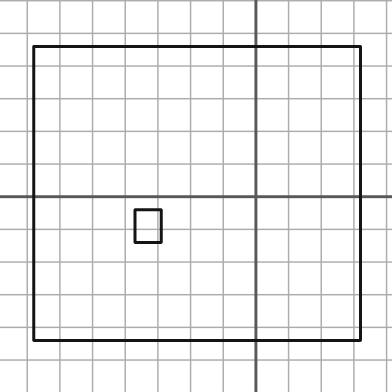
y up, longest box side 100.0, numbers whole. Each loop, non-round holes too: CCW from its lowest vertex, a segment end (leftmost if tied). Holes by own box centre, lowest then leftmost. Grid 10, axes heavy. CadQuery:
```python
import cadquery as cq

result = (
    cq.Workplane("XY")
    .moveTo(-68.0, -44.0)
    .lineTo(32.0, -44.0)
    .lineTo(32.0, 46.0)
    .lineTo(-68.0, 46.0)
    .close()
    .moveTo(-37.0, -14.0)
    .lineTo(-29.0, -14.0)
    .lineTo(-29.0, -4.0)
    .lineTo(-37.0, -4.0)
    .close()
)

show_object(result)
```